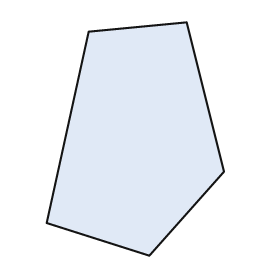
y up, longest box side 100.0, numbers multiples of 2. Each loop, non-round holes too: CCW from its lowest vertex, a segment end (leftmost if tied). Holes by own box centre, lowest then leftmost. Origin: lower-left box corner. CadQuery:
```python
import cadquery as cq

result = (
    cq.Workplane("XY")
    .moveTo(44.0, 0.0)
    .lineTo(76.0, 36.0)
    .lineTo(60.0, 100.0)
    .lineTo(18.0, 96.0)
    .lineTo(0.0, 14.0)
    .close()
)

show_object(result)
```